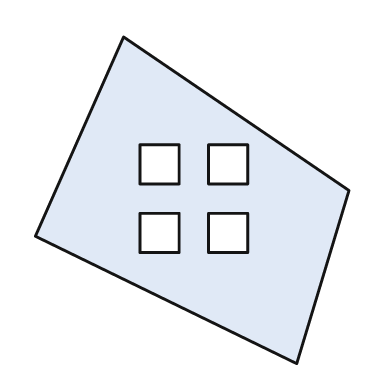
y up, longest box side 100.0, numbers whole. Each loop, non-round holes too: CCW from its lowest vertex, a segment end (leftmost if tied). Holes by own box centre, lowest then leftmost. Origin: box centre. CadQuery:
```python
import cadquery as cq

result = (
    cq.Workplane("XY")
    .moveTo(32.0, -50.0)
    .lineTo(48.0, 3.0)
    .lineTo(-21.0, 50.0)
    .lineTo(-48.0, -11.0)
    .close()
    .moveTo(-16.0, -16.0)
    .lineTo(-4.0, -16.0)
    .lineTo(-4.0, -4.0)
    .lineTo(-16.0, -4.0)
    .close()
    .moveTo(5.0, -16.0)
    .lineTo(17.0, -16.0)
    .lineTo(17.0, -4.0)
    .lineTo(5.0, -4.0)
    .close()
    .moveTo(-16.0, 5.0)
    .lineTo(-4.0, 5.0)
    .lineTo(-4.0, 17.0)
    .lineTo(-16.0, 17.0)
    .close()
    .moveTo(5.0, 5.0)
    .lineTo(17.0, 5.0)
    .lineTo(17.0, 17.0)
    .lineTo(5.0, 17.0)
    .close()
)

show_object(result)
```